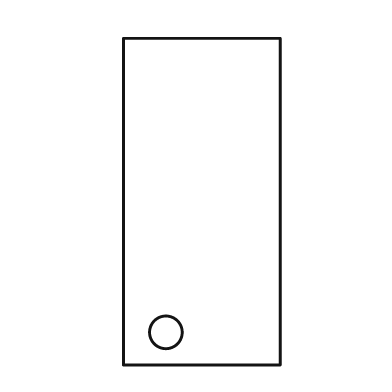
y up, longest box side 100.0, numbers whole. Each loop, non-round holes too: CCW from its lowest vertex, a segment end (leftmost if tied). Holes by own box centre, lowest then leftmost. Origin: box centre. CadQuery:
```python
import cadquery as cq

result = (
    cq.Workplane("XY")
    .moveTo(-24.0, -50.0)
    .lineTo(24.0, -50.0)
    .lineTo(24.0, 50.0)
    .lineTo(-24.0, 50.0)
    .close()
    .moveTo(-11.0, -40.0)
    .circle(5.0)
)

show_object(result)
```